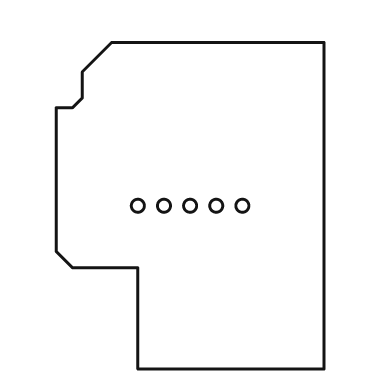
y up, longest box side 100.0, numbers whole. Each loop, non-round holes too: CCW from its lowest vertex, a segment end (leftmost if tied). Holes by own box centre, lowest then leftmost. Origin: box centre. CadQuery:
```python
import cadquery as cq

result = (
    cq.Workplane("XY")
    .moveTo(-16.0, -50.0)
    .lineTo(41.0, -50.0)
    .lineTo(41.0, 50.0)
    .lineTo(-24.0, 50.0)
    .lineTo(-33.0, 41.0)
    .lineTo(-33.0, 33.0)
    .lineTo(-36.0, 30.0)
    .lineTo(-41.0, 30.0)
    .lineTo(-41.0, -14.0)
    .lineTo(-36.0, -19.0)
    .lineTo(-16.0, -19.0)
    .close()
    .moveTo(-16.0, 0.0)
    .circle(2.0)
    .moveTo(-8.0, 0.0)
    .circle(2.0)
    .moveTo(0.0, 0.0)
    .circle(2.0)
    .moveTo(8.0, 0.0)
    .circle(2.0)
    .moveTo(16.0, 0.0)
    .circle(2.0)
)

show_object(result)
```